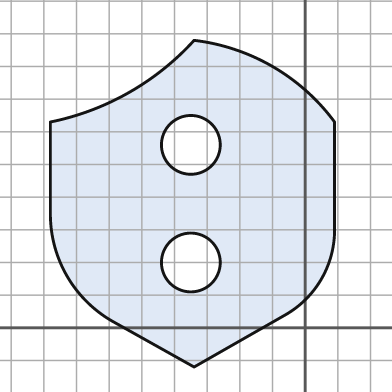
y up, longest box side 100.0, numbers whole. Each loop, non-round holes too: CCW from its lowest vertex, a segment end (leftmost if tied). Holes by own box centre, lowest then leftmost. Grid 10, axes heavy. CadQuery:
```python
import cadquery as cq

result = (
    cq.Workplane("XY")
    .moveTo(-34.0, -12.0)
    .lineTo(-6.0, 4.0)
    .threePointArc((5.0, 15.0), (9.0, 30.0))
    .lineTo(9.0, 63.0)
    .threePointArc((-10.0, 80.0), (-34.0, 88.0))
    .threePointArc((-54.0, 72.0), (-78.0, 63.0))
    .lineTo(-78.0, 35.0)
    .threePointArc((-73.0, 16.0), (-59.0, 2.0))
    .close()
    .moveTo(-35.0, 20.0)
    .circle(9.0)
    .moveTo(-35.0, 56.0)
    .circle(9.0)
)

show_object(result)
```